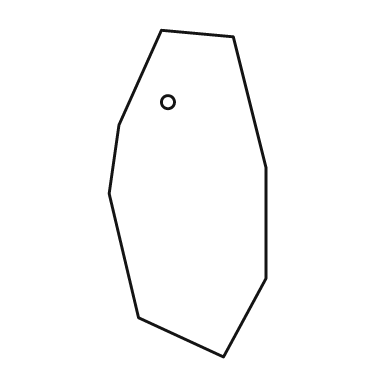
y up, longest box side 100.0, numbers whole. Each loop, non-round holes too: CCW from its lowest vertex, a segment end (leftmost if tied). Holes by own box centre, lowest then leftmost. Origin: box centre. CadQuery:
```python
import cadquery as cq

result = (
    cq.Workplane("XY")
    .moveTo(11.0, -50.0)
    .lineTo(24.0, -26.0)
    .lineTo(24.0, 8.0)
    .lineTo(14.0, 48.0)
    .lineTo(-8.0, 50.0)
    .lineTo(-21.0, 21.0)
    .lineTo(-24.0, 0.0)
    .lineTo(-15.0, -38.0)
    .close()
    .moveTo(-6.0, 28.0)
    .circle(2.0)
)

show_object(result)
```